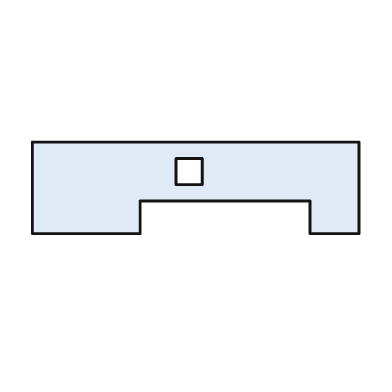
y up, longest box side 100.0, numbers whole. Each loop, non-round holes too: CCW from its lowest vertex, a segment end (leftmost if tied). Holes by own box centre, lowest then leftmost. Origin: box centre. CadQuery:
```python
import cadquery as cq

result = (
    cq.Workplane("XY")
    .moveTo(-50.0, -14.0)
    .lineTo(-17.0, -14.0)
    .lineTo(-17.0, -4.0)
    .lineTo(35.0, -4.0)
    .lineTo(35.0, -14.0)
    .lineTo(50.0, -14.0)
    .lineTo(50.0, 14.0)
    .lineTo(-50.0, 14.0)
    .close()
    .moveTo(-6.0, 1.0)
    .lineTo(2.0, 1.0)
    .lineTo(2.0, 9.0)
    .lineTo(-6.0, 9.0)
    .close()
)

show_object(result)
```